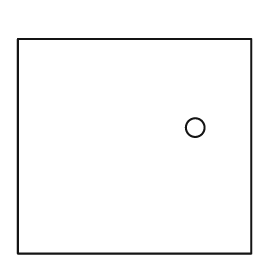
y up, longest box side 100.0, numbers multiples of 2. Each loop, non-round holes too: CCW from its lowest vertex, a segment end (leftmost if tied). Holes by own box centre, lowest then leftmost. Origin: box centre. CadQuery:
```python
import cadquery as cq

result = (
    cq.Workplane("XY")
    .moveTo(-50.0, -46.0)
    .lineTo(50.0, -46.0)
    .lineTo(50.0, 46.0)
    .lineTo(-50.0, 46.0)
    .close()
    .moveTo(26.0, 8.0)
    .circle(4.0)
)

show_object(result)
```